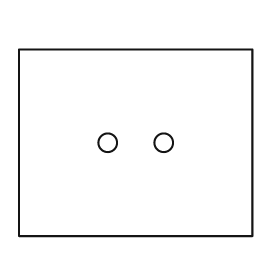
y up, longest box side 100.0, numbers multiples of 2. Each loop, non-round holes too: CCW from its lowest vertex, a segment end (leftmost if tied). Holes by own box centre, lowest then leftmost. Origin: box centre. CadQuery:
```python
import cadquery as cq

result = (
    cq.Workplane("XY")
    .moveTo(-50.0, -40.0)
    .lineTo(50.0, -40.0)
    .lineTo(50.0, 40.0)
    .lineTo(-50.0, 40.0)
    .close()
    .moveTo(-12.0, 0.0)
    .circle(4.0)
    .moveTo(12.0, 0.0)
    .circle(4.0)
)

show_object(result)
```